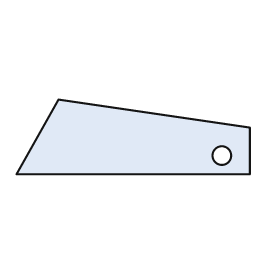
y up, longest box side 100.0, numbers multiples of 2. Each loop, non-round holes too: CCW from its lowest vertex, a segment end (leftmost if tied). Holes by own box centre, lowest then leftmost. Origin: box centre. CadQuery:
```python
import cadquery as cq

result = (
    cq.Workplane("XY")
    .moveTo(-50.0, -16.0)
    .lineTo(50.0, -16.0)
    .lineTo(50.0, 4.0)
    .lineTo(-32.0, 16.0)
    .close()
    .moveTo(38.0, -8.0)
    .circle(4.0)
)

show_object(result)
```